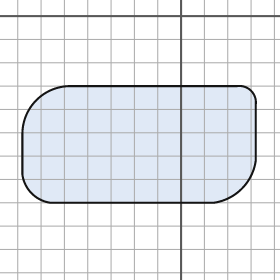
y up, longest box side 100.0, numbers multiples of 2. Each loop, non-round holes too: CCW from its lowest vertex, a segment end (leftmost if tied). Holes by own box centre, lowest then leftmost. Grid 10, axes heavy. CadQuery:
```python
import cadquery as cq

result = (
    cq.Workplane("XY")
    .moveTo(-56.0, -80.0)
    .lineTo(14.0, -80.0)
    .threePointArc((26.0, -74.0), (32.0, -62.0))
    .lineTo(32.0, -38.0)
    .threePointArc((30.0, -32.0), (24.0, -30.0))
    .lineTo(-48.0, -30.0)
    .threePointArc((-62.0, -36.0), (-68.0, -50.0))
    .lineTo(-68.0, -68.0)
    .threePointArc((-64.0, -76.0), (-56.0, -80.0))
    .close()
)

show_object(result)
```